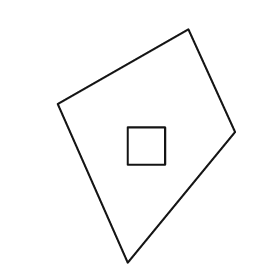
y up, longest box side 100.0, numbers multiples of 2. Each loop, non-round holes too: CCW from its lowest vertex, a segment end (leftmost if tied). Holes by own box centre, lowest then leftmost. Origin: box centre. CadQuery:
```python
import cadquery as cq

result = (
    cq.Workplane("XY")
    .moveTo(-8.0, -50.0)
    .lineTo(38.0, 6.0)
    .lineTo(18.0, 50.0)
    .lineTo(-38.0, 18.0)
    .close()
    .moveTo(-8.0, -8.0)
    .lineTo(8.0, -8.0)
    .lineTo(8.0, 8.0)
    .lineTo(-8.0, 8.0)
    .close()
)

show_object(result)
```